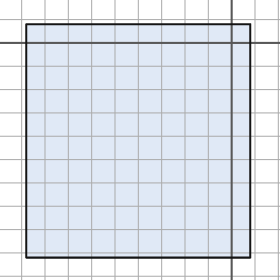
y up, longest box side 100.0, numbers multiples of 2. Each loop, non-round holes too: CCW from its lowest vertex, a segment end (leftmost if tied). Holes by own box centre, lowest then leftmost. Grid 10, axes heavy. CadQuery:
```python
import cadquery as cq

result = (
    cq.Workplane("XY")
    .moveTo(-88.0, -92.0)
    .lineTo(8.0, -92.0)
    .lineTo(8.0, 8.0)
    .lineTo(-88.0, 8.0)
    .close()
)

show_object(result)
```